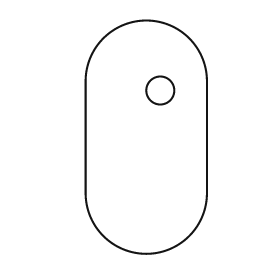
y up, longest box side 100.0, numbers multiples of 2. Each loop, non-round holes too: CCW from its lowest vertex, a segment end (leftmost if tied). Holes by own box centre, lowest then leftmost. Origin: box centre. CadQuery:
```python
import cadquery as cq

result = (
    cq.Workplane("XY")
    .moveTo(-26.0, -24.0)
    .threePointArc((0.0, -50.0), (26.0, -24.0))
    .lineTo(26.0, 24.0)
    .threePointArc((0.0, 50.0), (-26.0, 24.0))
    .close()
    .moveTo(6.0, 20.0)
    .circle(6.0)
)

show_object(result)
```